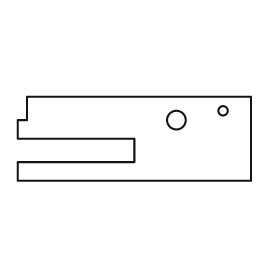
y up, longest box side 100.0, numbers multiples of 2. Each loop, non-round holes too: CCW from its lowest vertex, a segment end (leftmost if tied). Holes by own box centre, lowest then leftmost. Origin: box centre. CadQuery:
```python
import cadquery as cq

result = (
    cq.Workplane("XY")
    .moveTo(-50.0, -18.0)
    .lineTo(50.0, -18.0)
    .lineTo(50.0, 18.0)
    .lineTo(-46.0, 18.0)
    .lineTo(-46.0, 8.0)
    .lineTo(-50.0, 8.0)
    .lineTo(-50.0, 0.0)
    .lineTo(0.0, 0.0)
    .lineTo(0.0, -10.0)
    .lineTo(-50.0, -10.0)
    .close()
    .moveTo(18.0, 8.0)
    .circle(4.0)
    .moveTo(38.0, 12.0)
    .circle(2.0)
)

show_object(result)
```